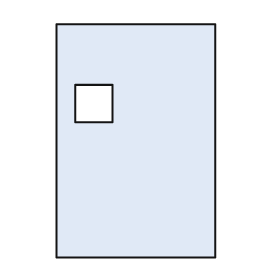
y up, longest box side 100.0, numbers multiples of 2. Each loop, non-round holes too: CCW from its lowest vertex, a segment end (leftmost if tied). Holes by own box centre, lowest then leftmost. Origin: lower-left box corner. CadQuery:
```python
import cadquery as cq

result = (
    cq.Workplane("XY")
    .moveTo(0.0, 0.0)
    .lineTo(68.0, 0.0)
    .lineTo(68.0, 100.0)
    .lineTo(0.0, 100.0)
    .close()
    .moveTo(8.0, 58.0)
    .lineTo(24.0, 58.0)
    .lineTo(24.0, 74.0)
    .lineTo(8.0, 74.0)
    .close()
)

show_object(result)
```